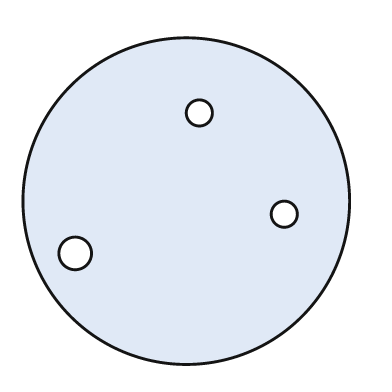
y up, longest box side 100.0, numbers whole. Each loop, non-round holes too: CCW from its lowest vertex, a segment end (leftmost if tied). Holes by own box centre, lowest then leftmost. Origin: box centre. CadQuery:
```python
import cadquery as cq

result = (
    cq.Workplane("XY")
    .moveTo(0.0, 0.0)
    .circle(50.0)
    .moveTo(-34.0, -16.0)
    .circle(5.0)
    .moveTo(30.0, -4.0)
    .circle(4.0)
    .moveTo(4.0, 27.0)
    .circle(4.0)
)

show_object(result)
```